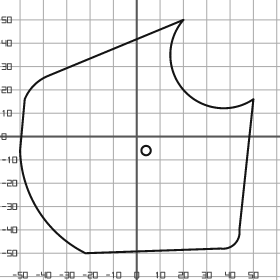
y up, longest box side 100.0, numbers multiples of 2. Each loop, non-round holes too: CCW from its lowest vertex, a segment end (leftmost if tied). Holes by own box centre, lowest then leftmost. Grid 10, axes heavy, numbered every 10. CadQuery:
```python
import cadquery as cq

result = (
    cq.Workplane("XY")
    .moveTo(-22.0, -50.0)
    .lineTo(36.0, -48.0)
    .threePointArc((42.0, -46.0), (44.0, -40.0))
    .lineTo(50.0, 16.0)
    .threePointArc((20.0, 20.0), (20.0, 50.0))
    .lineTo(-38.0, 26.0)
    .threePointArc((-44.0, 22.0), (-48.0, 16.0))
    .lineTo(-50.0, -6.0)
    .threePointArc((-42.0, -32.0), (-22.0, -50.0))
    .close()
    .moveTo(4.0, -6.0)
    .circle(2.0)
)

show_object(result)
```